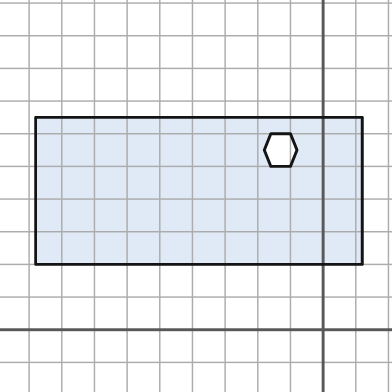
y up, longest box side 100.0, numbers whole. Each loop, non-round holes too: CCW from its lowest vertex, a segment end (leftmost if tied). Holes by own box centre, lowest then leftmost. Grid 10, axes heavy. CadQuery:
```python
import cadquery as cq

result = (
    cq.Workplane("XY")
    .moveTo(-88.0, 20.0)
    .lineTo(12.0, 20.0)
    .lineTo(12.0, 65.0)
    .lineTo(-88.0, 65.0)
    .close()
    .moveTo(-16.0, 50.0)
    .lineTo(-10.0, 50.0)
    .lineTo(-8.0, 55.0)
    .lineTo(-10.0, 60.0)
    .lineTo(-16.0, 60.0)
    .lineTo(-18.0, 55.0)
    .close()
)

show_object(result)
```